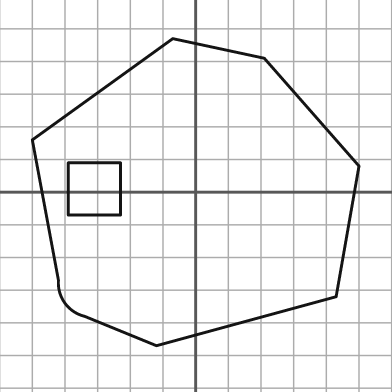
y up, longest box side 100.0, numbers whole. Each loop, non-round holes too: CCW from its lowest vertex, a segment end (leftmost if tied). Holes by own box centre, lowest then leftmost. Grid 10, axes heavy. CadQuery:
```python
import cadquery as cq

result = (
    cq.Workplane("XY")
    .moveTo(-12.0, -47.0)
    .lineTo(43.0, -32.0)
    .lineTo(50.0, 8.0)
    .lineTo(21.0, 41.0)
    .lineTo(-7.0, 47.0)
    .lineTo(-50.0, 16.0)
    .lineTo(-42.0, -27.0)
    .threePointArc((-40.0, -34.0), (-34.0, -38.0))
    .close()
    .moveTo(-39.0, -7.0)
    .lineTo(-23.0, -7.0)
    .lineTo(-23.0, 9.0)
    .lineTo(-39.0, 9.0)
    .close()
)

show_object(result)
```